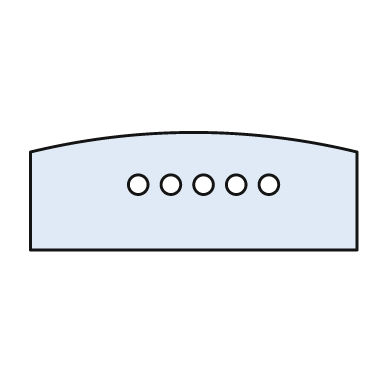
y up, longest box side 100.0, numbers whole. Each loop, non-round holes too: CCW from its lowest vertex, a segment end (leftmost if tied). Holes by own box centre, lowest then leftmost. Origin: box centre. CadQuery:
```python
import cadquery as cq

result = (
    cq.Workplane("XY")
    .moveTo(-50.0, -18.0)
    .lineTo(50.0, -18.0)
    .lineTo(50.0, 12.0)
    .threePointArc((0.0, 18.0), (-50.0, 12.0))
    .close()
    .moveTo(-17.0, 2.0)
    .circle(3.0)
    .moveTo(-7.0, 2.0)
    .circle(3.0)
    .moveTo(3.0, 2.0)
    .circle(3.0)
    .moveTo(13.0, 2.0)
    .circle(3.0)
    .moveTo(23.0, 2.0)
    .circle(3.0)
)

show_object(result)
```